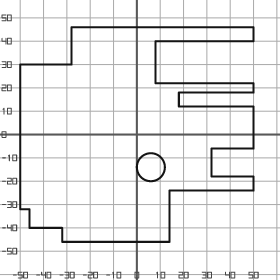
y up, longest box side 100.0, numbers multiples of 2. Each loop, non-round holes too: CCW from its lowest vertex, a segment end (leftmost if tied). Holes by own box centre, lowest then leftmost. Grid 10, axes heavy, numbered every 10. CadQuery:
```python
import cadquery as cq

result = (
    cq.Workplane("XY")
    .moveTo(-32.0, -46.0)
    .lineTo(14.0, -46.0)
    .lineTo(14.0, -24.0)
    .lineTo(50.0, -24.0)
    .lineTo(50.0, -18.0)
    .lineTo(32.0, -18.0)
    .lineTo(32.0, -6.0)
    .lineTo(50.0, -6.0)
    .lineTo(50.0, 12.0)
    .lineTo(18.0, 12.0)
    .lineTo(18.0, 18.0)
    .lineTo(50.0, 18.0)
    .lineTo(50.0, 22.0)
    .lineTo(8.0, 22.0)
    .lineTo(8.0, 40.0)
    .lineTo(50.0, 40.0)
    .lineTo(50.0, 46.0)
    .lineTo(-28.0, 46.0)
    .lineTo(-28.0, 30.0)
    .lineTo(-50.0, 30.0)
    .lineTo(-50.0, -32.0)
    .lineTo(-46.0, -32.0)
    .lineTo(-46.0, -40.0)
    .lineTo(-32.0, -40.0)
    .close()
    .moveTo(6.0, -14.0)
    .circle(6.0)
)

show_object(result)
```